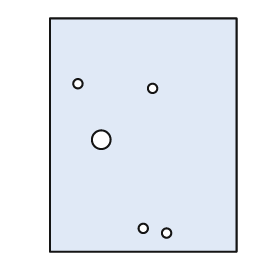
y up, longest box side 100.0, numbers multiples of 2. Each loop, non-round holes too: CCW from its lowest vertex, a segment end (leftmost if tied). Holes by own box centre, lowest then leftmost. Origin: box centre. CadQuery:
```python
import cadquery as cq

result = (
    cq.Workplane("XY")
    .moveTo(-40.0, -50.0)
    .lineTo(40.0, -50.0)
    .lineTo(40.0, 50.0)
    .lineTo(-40.0, 50.0)
    .close()
    .moveTo(10.0, -42.0)
    .circle(2.0)
    .moveTo(0.0, -40.0)
    .circle(2.0)
    .moveTo(-18.0, -2.0)
    .circle(4.0)
    .moveTo(4.0, 20.0)
    .circle(2.0)
    .moveTo(-28.0, 22.0)
    .circle(2.0)
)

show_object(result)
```